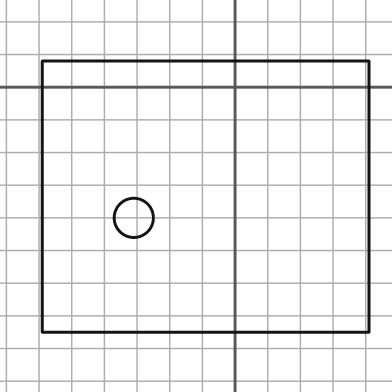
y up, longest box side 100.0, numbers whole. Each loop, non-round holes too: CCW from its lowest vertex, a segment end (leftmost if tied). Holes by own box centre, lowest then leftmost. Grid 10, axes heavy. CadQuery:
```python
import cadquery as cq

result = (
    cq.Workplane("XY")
    .moveTo(-59.0, -75.0)
    .lineTo(41.0, -75.0)
    .lineTo(41.0, 8.0)
    .lineTo(-59.0, 8.0)
    .close()
    .moveTo(-31.0, -40.0)
    .circle(6.0)
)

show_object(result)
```